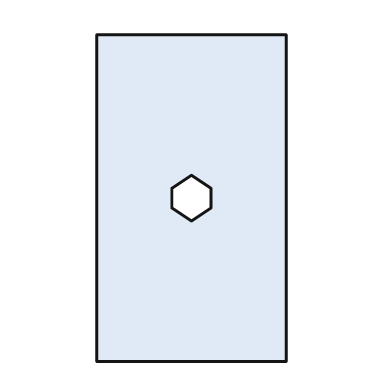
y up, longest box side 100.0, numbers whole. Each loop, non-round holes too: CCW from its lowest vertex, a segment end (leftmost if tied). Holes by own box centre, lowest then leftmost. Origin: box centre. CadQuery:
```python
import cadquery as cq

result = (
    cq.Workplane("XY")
    .moveTo(-29.0, -50.0)
    .lineTo(29.0, -50.0)
    .lineTo(29.0, 50.0)
    .lineTo(-29.0, 50.0)
    .close()
    .moveTo(0.0, -7.0)
    .lineTo(6.0, -3.0)
    .lineTo(6.0, 3.0)
    .lineTo(0.0, 7.0)
    .lineTo(-6.0, 3.0)
    .lineTo(-6.0, -3.0)
    .close()
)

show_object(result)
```